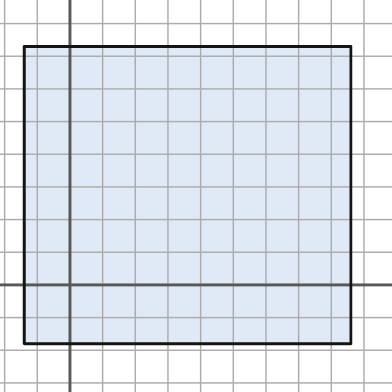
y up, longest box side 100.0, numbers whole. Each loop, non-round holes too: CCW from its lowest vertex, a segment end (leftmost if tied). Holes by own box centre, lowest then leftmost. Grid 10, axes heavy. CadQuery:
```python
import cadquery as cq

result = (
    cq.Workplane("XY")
    .moveTo(-14.0, -18.0)
    .lineTo(86.0, -18.0)
    .lineTo(86.0, 73.0)
    .lineTo(-14.0, 73.0)
    .close()
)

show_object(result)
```